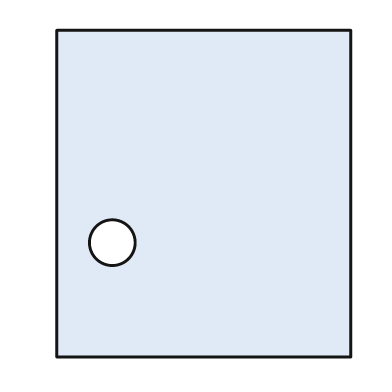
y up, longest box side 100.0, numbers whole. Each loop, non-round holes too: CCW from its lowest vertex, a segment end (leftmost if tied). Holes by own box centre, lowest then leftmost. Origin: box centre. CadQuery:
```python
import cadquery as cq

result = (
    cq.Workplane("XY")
    .moveTo(-45.0, -50.0)
    .lineTo(45.0, -50.0)
    .lineTo(45.0, 50.0)
    .lineTo(-45.0, 50.0)
    .close()
    .moveTo(-28.0, -15.0)
    .circle(7.0)
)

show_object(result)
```